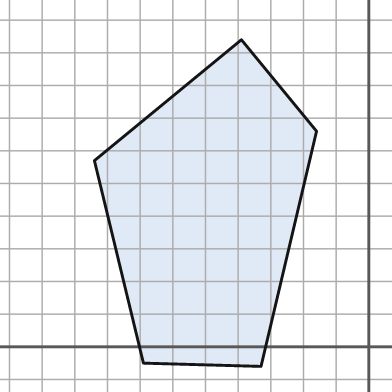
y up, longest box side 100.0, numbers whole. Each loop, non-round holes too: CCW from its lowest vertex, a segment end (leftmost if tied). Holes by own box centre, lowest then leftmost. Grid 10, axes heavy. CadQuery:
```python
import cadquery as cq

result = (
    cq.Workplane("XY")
    .moveTo(-33.0, -6.0)
    .lineTo(-16.0, 66.0)
    .lineTo(-39.0, 94.0)
    .lineTo(-84.0, 57.0)
    .lineTo(-69.0, -5.0)
    .close()
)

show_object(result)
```